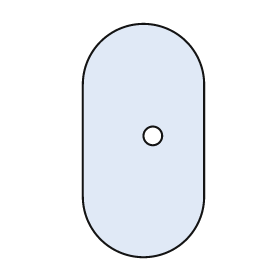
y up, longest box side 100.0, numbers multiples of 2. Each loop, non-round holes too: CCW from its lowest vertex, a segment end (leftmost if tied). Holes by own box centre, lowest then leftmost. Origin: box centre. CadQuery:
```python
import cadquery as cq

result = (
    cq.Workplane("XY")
    .moveTo(-26.0, -24.0)
    .threePointArc((0.0, -50.0), (26.0, -24.0))
    .lineTo(26.0, 24.0)
    .threePointArc((0.0, 50.0), (-26.0, 24.0))
    .close()
    .moveTo(4.0, 2.0)
    .circle(4.0)
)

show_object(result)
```